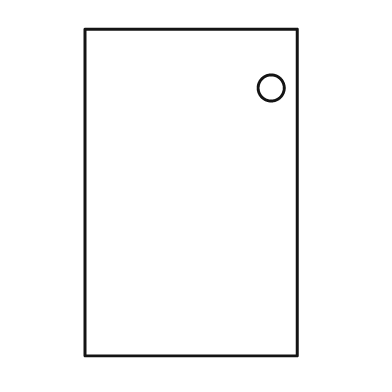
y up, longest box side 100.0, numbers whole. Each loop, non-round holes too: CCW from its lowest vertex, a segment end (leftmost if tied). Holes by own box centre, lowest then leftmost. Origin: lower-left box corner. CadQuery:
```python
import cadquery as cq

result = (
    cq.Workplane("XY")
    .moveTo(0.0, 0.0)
    .lineTo(65.0, 0.0)
    .lineTo(65.0, 100.0)
    .lineTo(0.0, 100.0)
    .close()
    .moveTo(57.0, 82.0)
    .circle(4.0)
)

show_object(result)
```